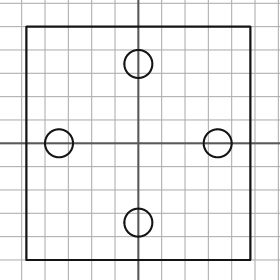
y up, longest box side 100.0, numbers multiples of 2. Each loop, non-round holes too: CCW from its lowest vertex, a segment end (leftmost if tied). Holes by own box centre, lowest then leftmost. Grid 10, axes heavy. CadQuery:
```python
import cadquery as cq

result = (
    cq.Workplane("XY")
    .moveTo(-48.0, -50.0)
    .lineTo(48.0, -50.0)
    .lineTo(48.0, 50.0)
    .lineTo(-48.0, 50.0)
    .close()
    .moveTo(0.0, -34.0)
    .circle(6.0)
    .moveTo(-34.0, 0.0)
    .circle(6.0)
    .moveTo(34.0, 0.0)
    .circle(6.0)
    .moveTo(0.0, 34.0)
    .circle(6.0)
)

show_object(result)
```